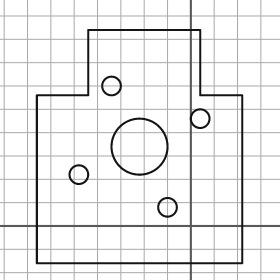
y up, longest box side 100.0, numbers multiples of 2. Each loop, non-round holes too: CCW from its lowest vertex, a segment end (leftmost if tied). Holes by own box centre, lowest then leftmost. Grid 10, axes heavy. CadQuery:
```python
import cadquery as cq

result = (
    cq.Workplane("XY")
    .moveTo(-66.0, -16.0)
    .lineTo(22.0, -16.0)
    .lineTo(22.0, 56.0)
    .lineTo(4.0, 56.0)
    .lineTo(4.0, 84.0)
    .lineTo(-44.0, 84.0)
    .lineTo(-44.0, 56.0)
    .lineTo(-66.0, 56.0)
    .close()
    .moveTo(-10.0, 8.0)
    .circle(4.0)
    .moveTo(-48.0, 22.0)
    .circle(4.0)
    .moveTo(-22.0, 34.0)
    .circle(12.0)
    .moveTo(4.0, 46.0)
    .circle(4.0)
    .moveTo(-34.0, 60.0)
    .circle(4.0)
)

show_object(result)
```